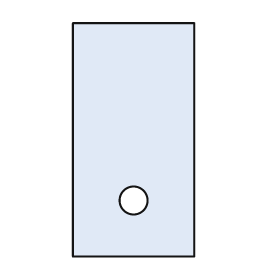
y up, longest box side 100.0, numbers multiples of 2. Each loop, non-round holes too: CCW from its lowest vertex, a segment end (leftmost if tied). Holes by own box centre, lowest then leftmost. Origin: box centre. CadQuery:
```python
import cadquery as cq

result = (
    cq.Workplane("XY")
    .moveTo(-26.0, -50.0)
    .lineTo(26.0, -50.0)
    .lineTo(26.0, 50.0)
    .lineTo(-26.0, 50.0)
    .close()
    .moveTo(0.0, -26.0)
    .circle(6.0)
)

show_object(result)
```